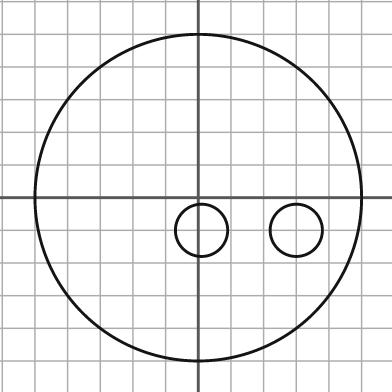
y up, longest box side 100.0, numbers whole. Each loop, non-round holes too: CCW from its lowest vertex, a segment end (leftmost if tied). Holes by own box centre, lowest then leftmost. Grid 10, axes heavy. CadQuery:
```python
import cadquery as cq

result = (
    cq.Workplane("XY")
    .moveTo(0.0, 0.0)
    .circle(50.0)
    .moveTo(1.0, -10.0)
    .circle(8.0)
    .moveTo(30.0, -10.0)
    .circle(8.0)
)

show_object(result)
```